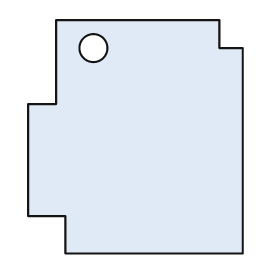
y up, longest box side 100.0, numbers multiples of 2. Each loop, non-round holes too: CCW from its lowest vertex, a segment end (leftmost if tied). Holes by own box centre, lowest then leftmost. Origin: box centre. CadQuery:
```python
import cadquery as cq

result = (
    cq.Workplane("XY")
    .moveTo(-30.0, -50.0)
    .lineTo(46.0, -50.0)
    .lineTo(46.0, 38.0)
    .lineTo(36.0, 38.0)
    .lineTo(36.0, 50.0)
    .lineTo(-34.0, 50.0)
    .lineTo(-34.0, 14.0)
    .lineTo(-46.0, 14.0)
    .lineTo(-46.0, -34.0)
    .lineTo(-30.0, -34.0)
    .close()
    .moveTo(-18.0, 38.0)
    .circle(6.0)
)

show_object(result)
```